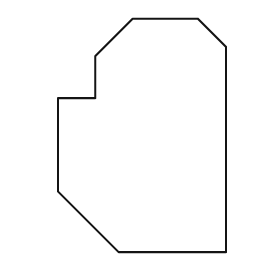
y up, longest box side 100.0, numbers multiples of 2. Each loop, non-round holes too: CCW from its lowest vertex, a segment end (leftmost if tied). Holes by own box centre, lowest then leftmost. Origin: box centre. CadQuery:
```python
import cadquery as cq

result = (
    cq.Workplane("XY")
    .moveTo(-10.0, -50.0)
    .lineTo(36.0, -50.0)
    .lineTo(36.0, 38.0)
    .lineTo(24.0, 50.0)
    .lineTo(-4.0, 50.0)
    .lineTo(-20.0, 34.0)
    .lineTo(-20.0, 16.0)
    .lineTo(-36.0, 16.0)
    .lineTo(-36.0, -24.0)
    .close()
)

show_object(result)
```